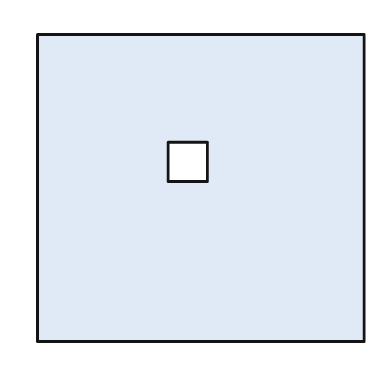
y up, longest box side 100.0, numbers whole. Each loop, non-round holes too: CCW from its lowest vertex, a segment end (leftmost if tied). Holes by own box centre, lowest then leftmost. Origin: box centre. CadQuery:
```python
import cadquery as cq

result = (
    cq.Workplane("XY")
    .moveTo(-50.0, -47.0)
    .lineTo(50.0, -47.0)
    .lineTo(50.0, 47.0)
    .lineTo(-50.0, 47.0)
    .close()
    .moveTo(-10.0, 2.0)
    .lineTo(2.0, 2.0)
    .lineTo(2.0, 14.0)
    .lineTo(-10.0, 14.0)
    .close()
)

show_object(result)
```